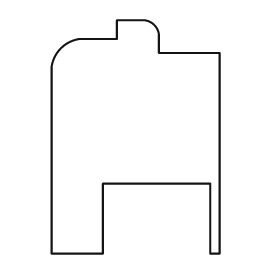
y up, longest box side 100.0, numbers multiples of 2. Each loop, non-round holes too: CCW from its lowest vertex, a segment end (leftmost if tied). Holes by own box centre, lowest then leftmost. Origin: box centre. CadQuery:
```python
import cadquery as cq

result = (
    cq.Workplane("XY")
    .moveTo(-36.0, -50.0)
    .lineTo(-14.0, -50.0)
    .lineTo(-14.0, -20.0)
    .lineTo(32.0, -20.0)
    .lineTo(32.0, -50.0)
    .lineTo(36.0, -50.0)
    .lineTo(36.0, 36.0)
    .lineTo(10.0, 36.0)
    .lineTo(10.0, 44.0)
    .threePointArc((8.0, 48.0), (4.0, 50.0))
    .lineTo(-8.0, 50.0)
    .lineTo(-8.0, 42.0)
    .lineTo(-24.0, 42.0)
    .threePointArc((-32.0, 38.0), (-36.0, 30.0))
    .close()
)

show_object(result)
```